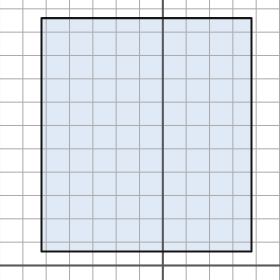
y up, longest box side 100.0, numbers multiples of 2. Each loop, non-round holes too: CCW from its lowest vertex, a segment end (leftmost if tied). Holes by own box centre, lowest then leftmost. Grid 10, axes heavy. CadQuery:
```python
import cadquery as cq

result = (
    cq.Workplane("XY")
    .moveTo(-52.0, 6.0)
    .lineTo(38.0, 6.0)
    .lineTo(38.0, 106.0)
    .lineTo(-52.0, 106.0)
    .close()
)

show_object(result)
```